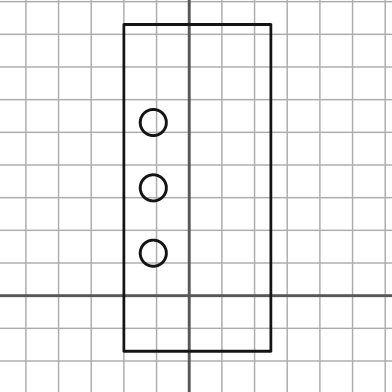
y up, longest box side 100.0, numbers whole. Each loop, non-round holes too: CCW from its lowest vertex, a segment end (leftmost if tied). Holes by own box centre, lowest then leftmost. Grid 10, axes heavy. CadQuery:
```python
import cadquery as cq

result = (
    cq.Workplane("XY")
    .moveTo(-20.0, -17.0)
    .lineTo(25.0, -17.0)
    .lineTo(25.0, 83.0)
    .lineTo(-20.0, 83.0)
    .close()
    .moveTo(-11.0, 13.0)
    .circle(4.0)
    .moveTo(-11.0, 33.0)
    .circle(4.0)
    .moveTo(-11.0, 53.0)
    .circle(4.0)
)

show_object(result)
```